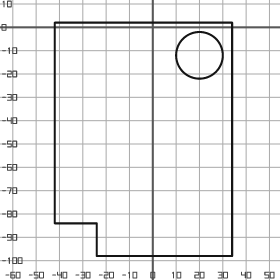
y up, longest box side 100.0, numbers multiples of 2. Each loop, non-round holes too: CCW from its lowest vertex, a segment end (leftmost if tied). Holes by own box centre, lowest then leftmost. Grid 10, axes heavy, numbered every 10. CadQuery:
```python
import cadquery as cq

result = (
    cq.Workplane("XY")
    .moveTo(-24.0, -98.0)
    .lineTo(34.0, -98.0)
    .lineTo(34.0, 2.0)
    .lineTo(-42.0, 2.0)
    .lineTo(-42.0, -84.0)
    .lineTo(-24.0, -84.0)
    .close()
    .moveTo(20.0, -12.0)
    .circle(10.0)
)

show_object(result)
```